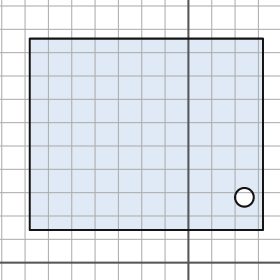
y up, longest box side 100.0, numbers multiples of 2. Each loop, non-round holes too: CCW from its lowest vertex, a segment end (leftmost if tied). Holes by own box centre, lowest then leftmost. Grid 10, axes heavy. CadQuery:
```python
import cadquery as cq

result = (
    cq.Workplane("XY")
    .moveTo(-68.0, 14.0)
    .lineTo(32.0, 14.0)
    .lineTo(32.0, 96.0)
    .lineTo(-68.0, 96.0)
    .close()
    .moveTo(24.0, 28.0)
    .circle(4.0)
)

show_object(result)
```